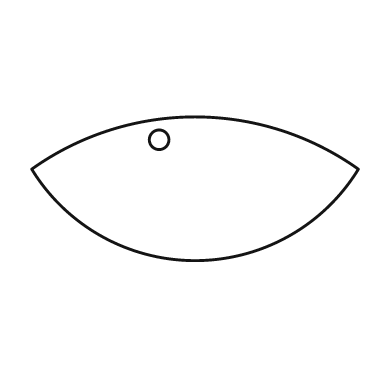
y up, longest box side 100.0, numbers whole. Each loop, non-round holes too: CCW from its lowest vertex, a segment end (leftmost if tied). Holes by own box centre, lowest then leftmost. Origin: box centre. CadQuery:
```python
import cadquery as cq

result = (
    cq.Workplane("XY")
    .moveTo(-50.0, 6.0)
    .threePointArc((0.0, -22.0), (50.0, 6.0))
    .threePointArc((0.0, 22.0), (-50.0, 6.0))
    .close()
    .moveTo(-11.0, 15.0)
    .circle(3.0)
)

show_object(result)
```